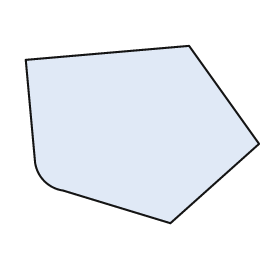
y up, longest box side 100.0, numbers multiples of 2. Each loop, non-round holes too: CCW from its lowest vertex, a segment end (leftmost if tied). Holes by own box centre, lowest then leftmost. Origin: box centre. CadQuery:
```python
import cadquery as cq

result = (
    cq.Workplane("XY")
    .moveTo(12.0, -38.0)
    .lineTo(50.0, -4.0)
    .lineTo(20.0, 38.0)
    .lineTo(-50.0, 32.0)
    .lineTo(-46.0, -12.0)
    .threePointArc((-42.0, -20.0), (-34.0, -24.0))
    .close()
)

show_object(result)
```